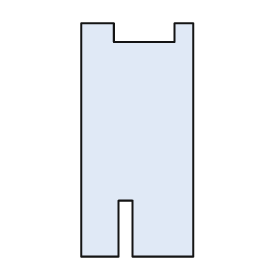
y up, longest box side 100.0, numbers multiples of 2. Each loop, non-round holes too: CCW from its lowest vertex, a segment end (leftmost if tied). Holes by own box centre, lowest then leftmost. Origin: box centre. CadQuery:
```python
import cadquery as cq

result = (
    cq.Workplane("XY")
    .moveTo(-24.0, -50.0)
    .lineTo(-8.0, -50.0)
    .lineTo(-8.0, -26.0)
    .lineTo(-2.0, -26.0)
    .lineTo(-2.0, -50.0)
    .lineTo(24.0, -50.0)
    .lineTo(24.0, 50.0)
    .lineTo(16.0, 50.0)
    .lineTo(16.0, 42.0)
    .lineTo(-10.0, 42.0)
    .lineTo(-10.0, 50.0)
    .lineTo(-24.0, 50.0)
    .close()
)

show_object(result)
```